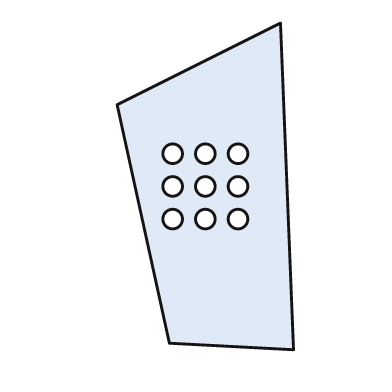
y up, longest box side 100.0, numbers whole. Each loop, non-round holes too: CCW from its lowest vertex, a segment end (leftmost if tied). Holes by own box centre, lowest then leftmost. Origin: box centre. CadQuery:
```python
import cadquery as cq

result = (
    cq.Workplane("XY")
    .moveTo(27.0, -50.0)
    .lineTo(23.0, 50.0)
    .lineTo(-27.0, 25.0)
    .lineTo(-11.0, -48.0)
    .close()
    .moveTo(-10.0, -10.0)
    .circle(3.0)
    .moveTo(0.0, -10.0)
    .circle(3.0)
    .moveTo(10.0, -10.0)
    .circle(3.0)
    .moveTo(-10.0, 0.0)
    .circle(3.0)
    .moveTo(0.0, 0.0)
    .circle(3.0)
    .moveTo(10.0, 0.0)
    .circle(3.0)
    .moveTo(-10.0, 10.0)
    .circle(3.0)
    .moveTo(0.0, 10.0)
    .circle(3.0)
    .moveTo(10.0, 10.0)
    .circle(3.0)
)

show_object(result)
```